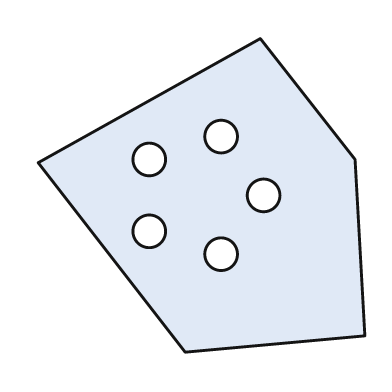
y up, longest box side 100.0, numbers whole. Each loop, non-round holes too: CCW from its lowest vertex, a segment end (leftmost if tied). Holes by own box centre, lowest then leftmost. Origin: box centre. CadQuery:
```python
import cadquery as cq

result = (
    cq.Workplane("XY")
    .moveTo(-5.0, -48.0)
    .lineTo(50.0, -43.0)
    .lineTo(47.0, 11.0)
    .lineTo(18.0, 48.0)
    .lineTo(-50.0, 10.0)
    .close()
    .moveTo(6.0, -18.0)
    .circle(5.0)
    .moveTo(-16.0, -11.0)
    .circle(5.0)
    .moveTo(19.0, 0.0)
    .circle(5.0)
    .moveTo(-16.0, 11.0)
    .circle(5.0)
    .moveTo(6.0, 18.0)
    .circle(5.0)
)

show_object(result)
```